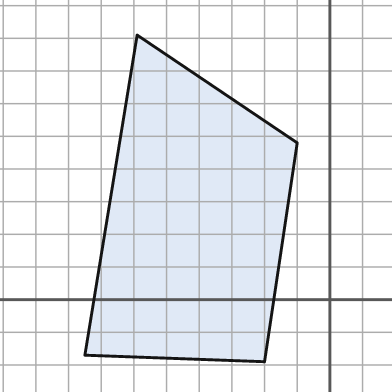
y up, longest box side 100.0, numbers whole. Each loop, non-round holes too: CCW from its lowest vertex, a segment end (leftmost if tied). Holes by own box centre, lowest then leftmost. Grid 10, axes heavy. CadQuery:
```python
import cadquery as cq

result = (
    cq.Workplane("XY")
    .moveTo(-20.0, -19.0)
    .lineTo(-10.0, 48.0)
    .lineTo(-59.0, 81.0)
    .lineTo(-75.0, -17.0)
    .close()
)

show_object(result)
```